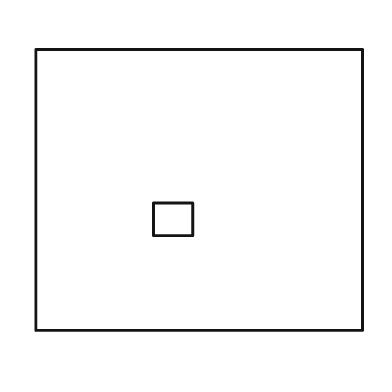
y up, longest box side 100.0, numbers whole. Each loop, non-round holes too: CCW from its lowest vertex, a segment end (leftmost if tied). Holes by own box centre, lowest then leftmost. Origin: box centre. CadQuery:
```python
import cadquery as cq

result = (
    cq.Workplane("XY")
    .moveTo(-50.0, -43.0)
    .lineTo(50.0, -43.0)
    .lineTo(50.0, 43.0)
    .lineTo(-50.0, 43.0)
    .close()
    .moveTo(-14.0, -14.0)
    .lineTo(-2.0, -14.0)
    .lineTo(-2.0, -4.0)
    .lineTo(-14.0, -4.0)
    .close()
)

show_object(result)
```